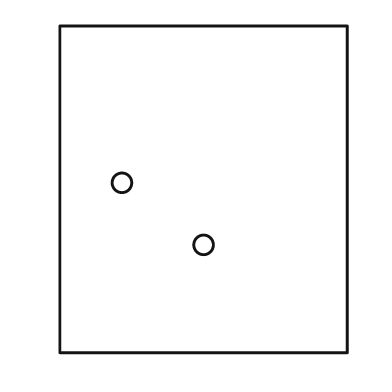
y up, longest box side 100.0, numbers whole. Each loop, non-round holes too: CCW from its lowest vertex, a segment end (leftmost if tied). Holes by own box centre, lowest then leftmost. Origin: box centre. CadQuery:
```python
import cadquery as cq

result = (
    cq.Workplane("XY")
    .moveTo(-44.0, -50.0)
    .lineTo(44.0, -50.0)
    .lineTo(44.0, 50.0)
    .lineTo(-44.0, 50.0)
    .close()
    .moveTo(0.0, -17.0)
    .circle(3.0)
    .moveTo(-25.0, 2.0)
    .circle(3.0)
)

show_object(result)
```